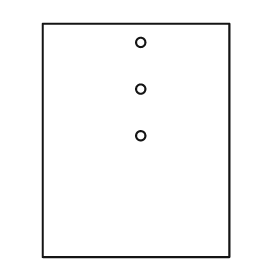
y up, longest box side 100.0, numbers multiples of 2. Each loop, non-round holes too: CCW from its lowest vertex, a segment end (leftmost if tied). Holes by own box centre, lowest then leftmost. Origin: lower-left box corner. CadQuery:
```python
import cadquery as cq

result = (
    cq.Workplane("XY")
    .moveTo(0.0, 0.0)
    .lineTo(80.0, 0.0)
    .lineTo(80.0, 100.0)
    .lineTo(0.0, 100.0)
    .close()
    .moveTo(42.0, 52.0)
    .circle(2.0)
    .moveTo(42.0, 72.0)
    .circle(2.0)
    .moveTo(42.0, 92.0)
    .circle(2.0)
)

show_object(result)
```